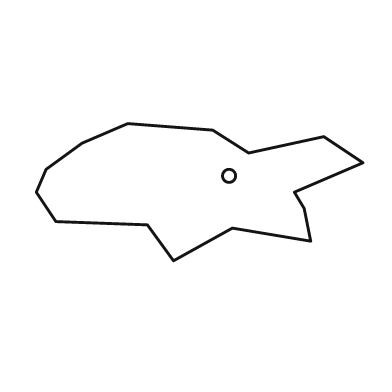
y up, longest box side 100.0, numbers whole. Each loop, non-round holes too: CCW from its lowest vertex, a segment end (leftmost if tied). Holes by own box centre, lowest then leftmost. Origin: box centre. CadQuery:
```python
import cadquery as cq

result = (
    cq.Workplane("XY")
    .moveTo(-8.0, -21.0)
    .lineTo(10.0, -11.0)
    .lineTo(34.0, -15.0)
    .lineTo(32.0, -5.0)
    .lineTo(29.0, 0.0)
    .lineTo(50.0, 9.0)
    .lineTo(38.0, 17.0)
    .lineTo(15.0, 12.0)
    .lineTo(4.0, 19.0)
    .lineTo(-22.0, 21.0)
    .lineTo(-36.0, 15.0)
    .lineTo(-47.0, 7.0)
    .lineTo(-50.0, 0.0)
    .lineTo(-44.0, -9.0)
    .lineTo(-16.0, -10.0)
    .close()
    .moveTo(9.0, 5.0)
    .circle(2.0)
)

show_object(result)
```